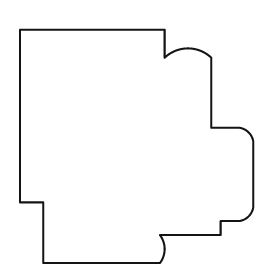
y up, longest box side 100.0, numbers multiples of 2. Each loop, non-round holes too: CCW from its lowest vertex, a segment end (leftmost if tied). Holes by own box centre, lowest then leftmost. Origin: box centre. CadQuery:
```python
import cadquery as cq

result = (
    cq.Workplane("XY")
    .moveTo(-40.0, -50.0)
    .lineTo(10.0, -50.0)
    .threePointArc((12.0, -44.0), (10.0, -38.0))
    .lineTo(36.0, -38.0)
    .lineTo(36.0, -32.0)
    .lineTo(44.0, -32.0)
    .threePointArc((48.0, -30.0), (50.0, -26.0))
    .lineTo(50.0, 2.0)
    .threePointArc((48.0, 6.0), (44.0, 8.0))
    .lineTo(32.0, 8.0)
    .lineTo(32.0, 38.0)
    .threePointArc((22.0, 42.0), (12.0, 38.0))
    .lineTo(12.0, 50.0)
    .lineTo(-50.0, 50.0)
    .lineTo(-50.0, -24.0)
    .lineTo(-40.0, -24.0)
    .close()
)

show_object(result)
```